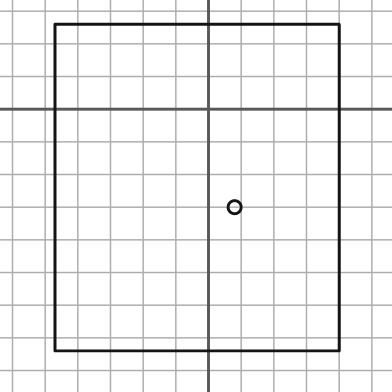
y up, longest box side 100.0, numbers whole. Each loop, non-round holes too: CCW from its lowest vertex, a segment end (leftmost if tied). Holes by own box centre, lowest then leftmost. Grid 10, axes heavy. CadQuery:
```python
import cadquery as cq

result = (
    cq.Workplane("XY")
    .moveTo(-47.0, -74.0)
    .lineTo(40.0, -74.0)
    .lineTo(40.0, 26.0)
    .lineTo(-47.0, 26.0)
    .close()
    .moveTo(8.0, -30.0)
    .circle(2.0)
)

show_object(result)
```